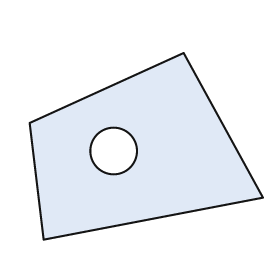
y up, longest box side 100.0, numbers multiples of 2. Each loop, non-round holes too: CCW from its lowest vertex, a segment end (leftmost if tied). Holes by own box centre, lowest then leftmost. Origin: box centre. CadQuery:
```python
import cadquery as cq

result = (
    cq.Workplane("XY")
    .moveTo(-44.0, -40.0)
    .lineTo(50.0, -22.0)
    .lineTo(16.0, 40.0)
    .lineTo(-50.0, 10.0)
    .close()
    .moveTo(-14.0, -2.0)
    .circle(10.0)
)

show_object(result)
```